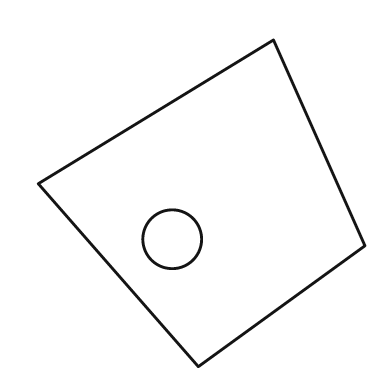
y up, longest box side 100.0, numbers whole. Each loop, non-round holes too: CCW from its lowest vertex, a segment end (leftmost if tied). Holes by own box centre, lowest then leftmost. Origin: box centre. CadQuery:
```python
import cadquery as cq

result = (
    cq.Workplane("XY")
    .moveTo(-1.0, -50.0)
    .lineTo(50.0, -13.0)
    .lineTo(22.0, 50.0)
    .lineTo(-50.0, 6.0)
    .close()
    .moveTo(-9.0, -11.0)
    .circle(9.0)
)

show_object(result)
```